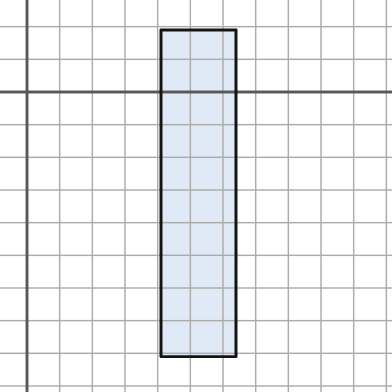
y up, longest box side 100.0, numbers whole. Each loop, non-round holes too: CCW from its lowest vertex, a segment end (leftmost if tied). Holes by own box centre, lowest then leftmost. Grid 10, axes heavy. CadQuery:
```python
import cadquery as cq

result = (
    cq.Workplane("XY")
    .moveTo(41.0, -81.0)
    .lineTo(64.0, -81.0)
    .lineTo(64.0, 19.0)
    .lineTo(41.0, 19.0)
    .close()
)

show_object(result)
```